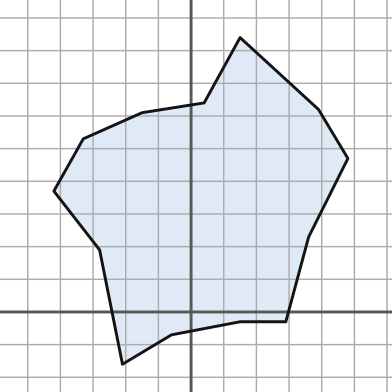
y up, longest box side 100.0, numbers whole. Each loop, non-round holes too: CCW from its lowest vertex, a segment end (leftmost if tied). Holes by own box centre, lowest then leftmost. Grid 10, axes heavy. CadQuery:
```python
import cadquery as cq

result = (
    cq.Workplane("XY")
    .moveTo(-21.0, -16.0)
    .lineTo(-6.0, -7.0)
    .lineTo(15.0, -3.0)
    .lineTo(29.0, -3.0)
    .lineTo(36.0, 23.0)
    .lineTo(48.0, 47.0)
    .lineTo(39.0, 62.0)
    .lineTo(15.0, 84.0)
    .lineTo(4.0, 64.0)
    .lineTo(-15.0, 61.0)
    .lineTo(-33.0, 53.0)
    .lineTo(-42.0, 37.0)
    .lineTo(-28.0, 19.0)
    .close()
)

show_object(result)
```